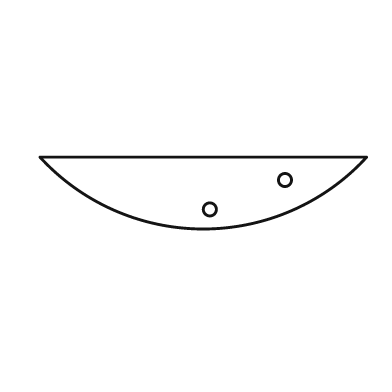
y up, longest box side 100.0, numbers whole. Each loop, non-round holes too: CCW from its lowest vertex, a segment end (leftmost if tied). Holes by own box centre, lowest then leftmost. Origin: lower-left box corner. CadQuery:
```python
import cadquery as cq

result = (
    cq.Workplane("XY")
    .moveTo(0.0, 22.0)
    .threePointArc((50.0, 0.0), (100.0, 22.0))
    .close()
    .moveTo(52.0, 6.0)
    .circle(2.0)
    .moveTo(75.0, 15.0)
    .circle(2.0)
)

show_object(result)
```